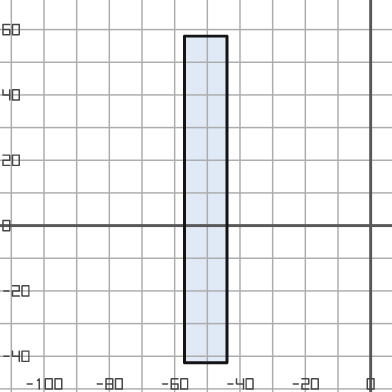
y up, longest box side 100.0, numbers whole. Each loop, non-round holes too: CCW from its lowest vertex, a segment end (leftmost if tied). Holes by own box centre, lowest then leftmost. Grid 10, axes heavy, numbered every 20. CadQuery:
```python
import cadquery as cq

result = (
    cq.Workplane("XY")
    .moveTo(-57.0, -42.0)
    .lineTo(-44.0, -42.0)
    .lineTo(-44.0, 58.0)
    .lineTo(-57.0, 58.0)
    .close()
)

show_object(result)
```